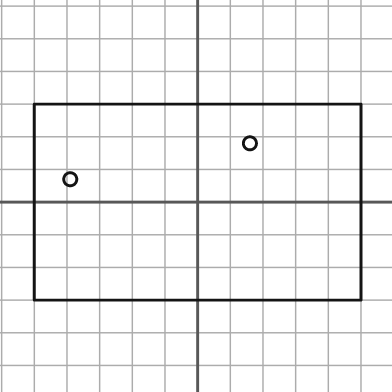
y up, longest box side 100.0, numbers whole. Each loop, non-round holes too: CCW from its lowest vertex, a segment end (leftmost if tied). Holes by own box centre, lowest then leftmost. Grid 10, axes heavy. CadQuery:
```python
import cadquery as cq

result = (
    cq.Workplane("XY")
    .moveTo(-50.0, -30.0)
    .lineTo(50.0, -30.0)
    .lineTo(50.0, 30.0)
    .lineTo(-50.0, 30.0)
    .close()
    .moveTo(-39.0, 7.0)
    .circle(2.0)
    .moveTo(16.0, 18.0)
    .circle(2.0)
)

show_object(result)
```